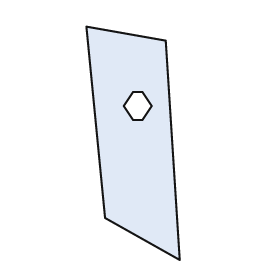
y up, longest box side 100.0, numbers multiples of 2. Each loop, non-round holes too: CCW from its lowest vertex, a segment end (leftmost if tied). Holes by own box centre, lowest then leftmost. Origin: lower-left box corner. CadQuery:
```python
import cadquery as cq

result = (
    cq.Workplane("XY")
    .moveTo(40.0, 0.0)
    .lineTo(34.0, 94.0)
    .lineTo(0.0, 100.0)
    .lineTo(8.0, 18.0)
    .close()
    .moveTo(20.0, 60.0)
    .lineTo(24.0, 60.0)
    .lineTo(28.0, 66.0)
    .lineTo(24.0, 72.0)
    .lineTo(20.0, 72.0)
    .lineTo(16.0, 66.0)
    .close()
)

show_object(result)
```